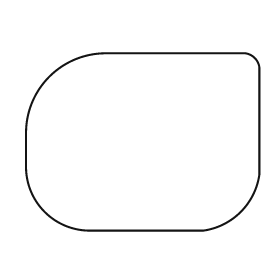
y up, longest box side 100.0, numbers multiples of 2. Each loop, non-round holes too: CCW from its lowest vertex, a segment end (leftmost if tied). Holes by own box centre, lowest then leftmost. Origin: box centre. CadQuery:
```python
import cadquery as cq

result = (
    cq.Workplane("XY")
    .moveTo(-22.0, -38.0)
    .lineTo(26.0, -38.0)
    .threePointArc((42.0, -30.0), (50.0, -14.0))
    .lineTo(50.0, 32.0)
    .threePointArc((48.0, 36.0), (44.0, 38.0))
    .lineTo(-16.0, 38.0)
    .threePointArc((-40.0, 28.0), (-50.0, 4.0))
    .lineTo(-50.0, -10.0)
    .threePointArc((-42.0, -30.0), (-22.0, -38.0))
    .close()
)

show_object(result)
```